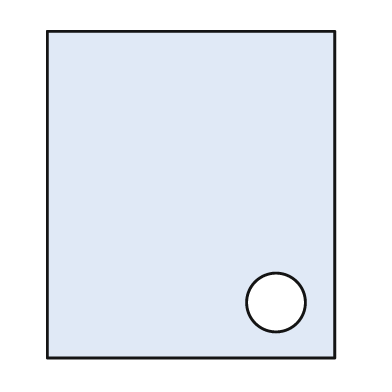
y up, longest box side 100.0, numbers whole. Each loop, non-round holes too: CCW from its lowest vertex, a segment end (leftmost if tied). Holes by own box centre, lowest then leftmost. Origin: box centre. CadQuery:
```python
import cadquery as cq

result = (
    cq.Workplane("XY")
    .moveTo(-44.0, -50.0)
    .lineTo(44.0, -50.0)
    .lineTo(44.0, 50.0)
    .lineTo(-44.0, 50.0)
    .close()
    .moveTo(26.0, -33.0)
    .circle(9.0)
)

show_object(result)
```